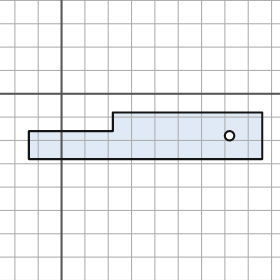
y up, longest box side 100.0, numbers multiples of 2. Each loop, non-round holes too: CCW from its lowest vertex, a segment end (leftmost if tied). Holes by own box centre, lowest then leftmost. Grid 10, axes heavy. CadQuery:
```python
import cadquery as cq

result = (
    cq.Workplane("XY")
    .moveTo(-14.0, -28.0)
    .lineTo(86.0, -28.0)
    .lineTo(86.0, -8.0)
    .lineTo(22.0, -8.0)
    .lineTo(22.0, -16.0)
    .lineTo(-14.0, -16.0)
    .close()
    .moveTo(72.0, -18.0)
    .circle(2.0)
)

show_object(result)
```